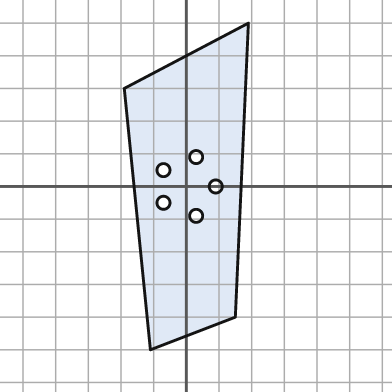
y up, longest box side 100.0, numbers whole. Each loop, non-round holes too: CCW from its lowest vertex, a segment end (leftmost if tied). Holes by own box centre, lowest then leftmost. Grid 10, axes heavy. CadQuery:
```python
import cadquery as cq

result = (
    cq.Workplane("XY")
    .moveTo(-11.0, -50.0)
    .lineTo(15.0, -40.0)
    .lineTo(19.0, 50.0)
    .lineTo(-19.0, 30.0)
    .close()
    .moveTo(3.0, -9.0)
    .circle(2.0)
    .moveTo(-7.0, -5.0)
    .circle(2.0)
    .moveTo(9.0, 0.0)
    .circle(2.0)
    .moveTo(-7.0, 5.0)
    .circle(2.0)
    .moveTo(3.0, 9.0)
    .circle(2.0)
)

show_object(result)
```